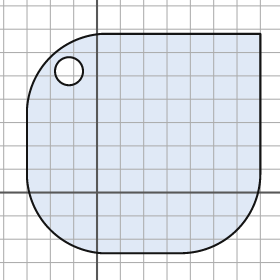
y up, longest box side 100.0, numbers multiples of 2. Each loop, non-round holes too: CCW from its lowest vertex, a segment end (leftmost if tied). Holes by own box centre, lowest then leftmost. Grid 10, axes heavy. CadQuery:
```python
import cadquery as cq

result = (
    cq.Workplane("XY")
    .moveTo(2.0, -26.0)
    .lineTo(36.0, -26.0)
    .threePointArc((60.0, -16.0), (70.0, 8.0))
    .lineTo(70.0, 68.0)
    .lineTo(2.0, 68.0)
    .threePointArc((-20.0, 58.0), (-30.0, 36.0))
    .lineTo(-30.0, 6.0)
    .threePointArc((-20.0, -16.0), (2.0, -26.0))
    .close()
    .moveTo(-12.0, 52.0)
    .circle(6.0)
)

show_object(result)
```